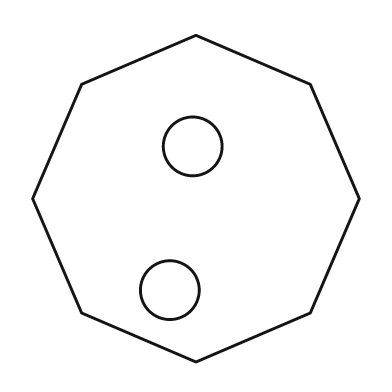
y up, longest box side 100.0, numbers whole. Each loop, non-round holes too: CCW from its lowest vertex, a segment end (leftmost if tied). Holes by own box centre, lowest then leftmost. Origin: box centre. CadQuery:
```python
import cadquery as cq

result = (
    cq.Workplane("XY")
    .moveTo(0.0, -50.0)
    .lineTo(35.0, -35.0)
    .lineTo(50.0, 0.0)
    .lineTo(35.0, 35.0)
    .lineTo(0.0, 50.0)
    .lineTo(-35.0, 35.0)
    .lineTo(-50.0, 0.0)
    .lineTo(-35.0, -35.0)
    .close()
    .moveTo(-8.0, -28.0)
    .circle(9.0)
    .moveTo(-1.0, 16.0)
    .circle(9.0)
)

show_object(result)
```